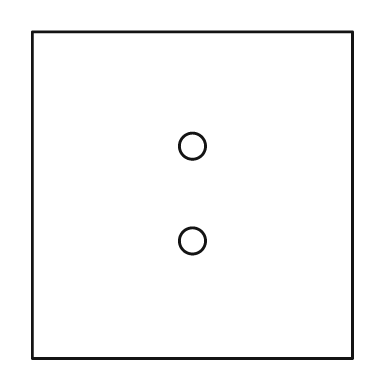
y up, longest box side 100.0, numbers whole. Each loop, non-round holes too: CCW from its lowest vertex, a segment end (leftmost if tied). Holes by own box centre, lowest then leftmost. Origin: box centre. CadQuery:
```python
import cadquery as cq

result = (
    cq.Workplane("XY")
    .moveTo(-49.0, -50.0)
    .lineTo(49.0, -50.0)
    .lineTo(49.0, 50.0)
    .lineTo(-49.0, 50.0)
    .close()
    .moveTo(0.0, -14.0)
    .circle(4.0)
    .moveTo(0.0, 15.0)
    .circle(4.0)
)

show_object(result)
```